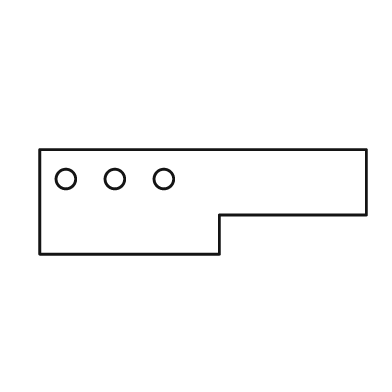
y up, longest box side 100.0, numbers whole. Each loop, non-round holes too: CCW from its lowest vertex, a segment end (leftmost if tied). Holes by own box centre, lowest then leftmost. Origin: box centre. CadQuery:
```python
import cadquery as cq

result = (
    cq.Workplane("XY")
    .moveTo(-50.0, -16.0)
    .lineTo(5.0, -16.0)
    .lineTo(5.0, -4.0)
    .lineTo(50.0, -4.0)
    .lineTo(50.0, 16.0)
    .lineTo(-50.0, 16.0)
    .close()
    .moveTo(-42.0, 7.0)
    .circle(3.0)
    .moveTo(-27.0, 7.0)
    .circle(3.0)
    .moveTo(-12.0, 7.0)
    .circle(3.0)
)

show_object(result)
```